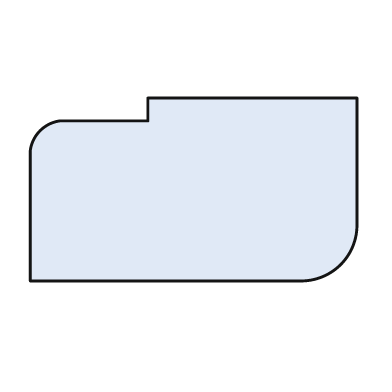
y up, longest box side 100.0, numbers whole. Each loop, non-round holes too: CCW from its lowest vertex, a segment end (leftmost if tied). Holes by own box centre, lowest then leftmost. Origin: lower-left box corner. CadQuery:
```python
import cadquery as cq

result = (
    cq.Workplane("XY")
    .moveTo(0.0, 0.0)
    .lineTo(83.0, 0.0)
    .threePointArc((95.0, 5.0), (100.0, 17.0))
    .lineTo(100.0, 56.0)
    .lineTo(36.0, 56.0)
    .lineTo(36.0, 49.0)
    .lineTo(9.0, 49.0)
    .threePointArc((3.0, 46.0), (0.0, 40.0))
    .close()
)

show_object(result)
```